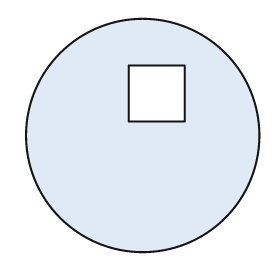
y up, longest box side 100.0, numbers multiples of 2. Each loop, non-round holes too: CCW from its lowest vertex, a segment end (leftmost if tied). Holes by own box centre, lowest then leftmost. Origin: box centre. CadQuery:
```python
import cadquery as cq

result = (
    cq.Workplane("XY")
    .moveTo(0.0, 0.0)
    .circle(50.0)
    .moveTo(-6.0, 6.0)
    .lineTo(18.0, 6.0)
    .lineTo(18.0, 30.0)
    .lineTo(-6.0, 30.0)
    .close()
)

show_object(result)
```